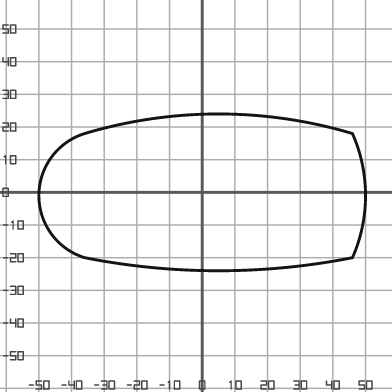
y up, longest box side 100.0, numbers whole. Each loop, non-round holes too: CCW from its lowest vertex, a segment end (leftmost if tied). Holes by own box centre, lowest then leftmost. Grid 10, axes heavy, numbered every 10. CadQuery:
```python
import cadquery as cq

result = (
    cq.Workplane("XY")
    .moveTo(-36.0, -20.0)
    .threePointArc((5.0, -24.0), (46.0, -20.0))
    .threePointArc((50.0, -1.0), (46.0, 18.0))
    .threePointArc((5.0, 24.0), (-36.0, 18.0))
    .threePointArc((-50.0, -1.0), (-36.0, -20.0))
    .close()
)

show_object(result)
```